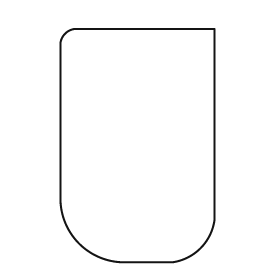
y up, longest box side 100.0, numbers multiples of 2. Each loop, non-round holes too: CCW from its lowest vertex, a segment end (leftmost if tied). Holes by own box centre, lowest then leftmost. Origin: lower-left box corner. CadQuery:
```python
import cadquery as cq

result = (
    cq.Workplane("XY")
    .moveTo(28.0, 0.0)
    .lineTo(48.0, 0.0)
    .threePointArc((60.0, 6.0), (66.0, 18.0))
    .lineTo(66.0, 100.0)
    .lineTo(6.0, 100.0)
    .threePointArc((2.0, 98.0), (0.0, 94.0))
    .lineTo(0.0, 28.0)
    .threePointArc((8.0, 8.0), (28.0, 0.0))
    .close()
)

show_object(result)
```